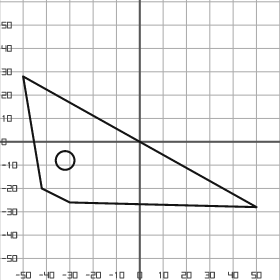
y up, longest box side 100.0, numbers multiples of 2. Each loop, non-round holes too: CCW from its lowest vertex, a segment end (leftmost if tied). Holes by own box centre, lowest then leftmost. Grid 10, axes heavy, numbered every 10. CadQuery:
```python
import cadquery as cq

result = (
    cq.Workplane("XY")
    .moveTo(50.0, -28.0)
    .lineTo(-50.0, 28.0)
    .lineTo(-42.0, -20.0)
    .lineTo(-30.0, -26.0)
    .close()
    .moveTo(-32.0, -8.0)
    .circle(4.0)
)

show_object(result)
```